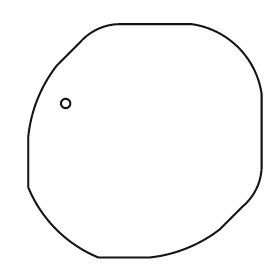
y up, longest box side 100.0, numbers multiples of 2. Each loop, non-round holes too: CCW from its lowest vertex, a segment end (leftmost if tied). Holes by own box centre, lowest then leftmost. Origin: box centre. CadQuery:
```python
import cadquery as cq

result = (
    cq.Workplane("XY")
    .moveTo(-20.0, -50.0)
    .lineTo(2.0, -50.0)
    .threePointArc((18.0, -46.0), (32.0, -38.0))
    .lineTo(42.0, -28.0)
    .threePointArc((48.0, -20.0), (50.0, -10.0))
    .lineTo(50.0, 20.0)
    .threePointArc((40.0, 40.0), (20.0, 50.0))
    .lineTo(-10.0, 50.0)
    .threePointArc((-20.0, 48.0), (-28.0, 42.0))
    .lineTo(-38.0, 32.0)
    .threePointArc((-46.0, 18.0), (-50.0, 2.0))
    .lineTo(-50.0, -20.0)
    .threePointArc((-38.0, -38.0), (-20.0, -50.0))
    .close()
    .moveTo(-34.0, 16.0)
    .circle(2.0)
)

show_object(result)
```